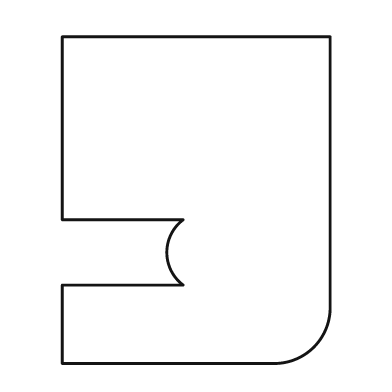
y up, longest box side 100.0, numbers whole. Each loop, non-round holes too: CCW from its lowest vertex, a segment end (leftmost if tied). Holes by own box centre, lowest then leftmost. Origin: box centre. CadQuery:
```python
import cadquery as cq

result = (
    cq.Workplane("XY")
    .moveTo(-41.0, -50.0)
    .lineTo(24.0, -50.0)
    .threePointArc((36.0, -45.0), (41.0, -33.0))
    .lineTo(41.0, 50.0)
    .lineTo(-41.0, 50.0)
    .lineTo(-41.0, -6.0)
    .lineTo(-4.0, -6.0)
    .threePointArc((-9.0, -16.0), (-4.0, -26.0))
    .lineTo(-41.0, -26.0)
    .close()
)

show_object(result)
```